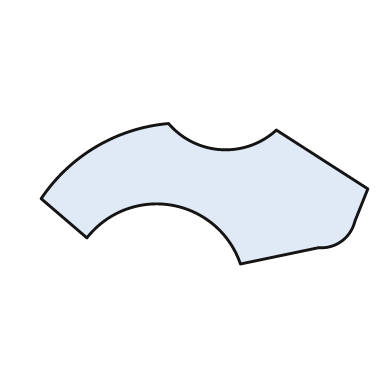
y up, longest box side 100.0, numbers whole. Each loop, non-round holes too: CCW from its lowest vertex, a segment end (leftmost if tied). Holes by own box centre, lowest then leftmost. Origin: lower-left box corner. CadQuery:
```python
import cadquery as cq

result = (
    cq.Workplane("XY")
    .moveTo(61.0, 0.0)
    .lineTo(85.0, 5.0)
    .threePointArc((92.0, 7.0), (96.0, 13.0))
    .lineTo(100.0, 23.0)
    .lineTo(72.0, 41.0)
    .threePointArc((55.0, 35.0), (39.0, 43.0))
    .threePointArc((17.0, 36.0), (0.0, 20.0))
    .lineTo(14.0, 8.0)
    .threePointArc((40.0, 18.0), (61.0, 0.0))
    .close()
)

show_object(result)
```